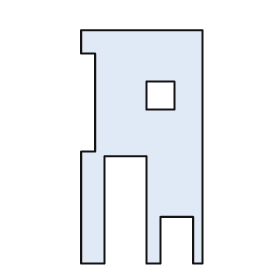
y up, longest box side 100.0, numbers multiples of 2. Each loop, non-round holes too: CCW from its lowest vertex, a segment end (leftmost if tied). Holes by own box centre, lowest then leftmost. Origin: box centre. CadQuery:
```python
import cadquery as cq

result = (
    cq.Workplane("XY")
    .moveTo(-26.0, -50.0)
    .lineTo(-16.0, -50.0)
    .lineTo(-16.0, -4.0)
    .lineTo(2.0, -4.0)
    .lineTo(2.0, -50.0)
    .lineTo(8.0, -50.0)
    .lineTo(8.0, -30.0)
    .lineTo(22.0, -30.0)
    .lineTo(22.0, -50.0)
    .lineTo(26.0, -50.0)
    .lineTo(26.0, 50.0)
    .lineTo(-26.0, 50.0)
    .lineTo(-26.0, 40.0)
    .lineTo(-20.0, 40.0)
    .lineTo(-20.0, -2.0)
    .lineTo(-26.0, -2.0)
    .close()
    .moveTo(2.0, 16.0)
    .lineTo(14.0, 16.0)
    .lineTo(14.0, 28.0)
    .lineTo(2.0, 28.0)
    .close()
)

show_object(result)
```